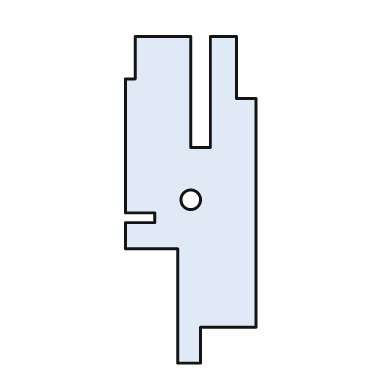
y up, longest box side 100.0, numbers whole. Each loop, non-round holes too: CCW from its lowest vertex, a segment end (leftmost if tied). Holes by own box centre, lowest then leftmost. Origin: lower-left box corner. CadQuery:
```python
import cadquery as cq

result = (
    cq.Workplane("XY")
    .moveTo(16.0, 0.0)
    .lineTo(23.0, 0.0)
    .lineTo(23.0, 11.0)
    .lineTo(40.0, 11.0)
    .lineTo(40.0, 81.0)
    .lineTo(34.0, 81.0)
    .lineTo(34.0, 100.0)
    .lineTo(26.0, 100.0)
    .lineTo(26.0, 66.0)
    .lineTo(20.0, 66.0)
    .lineTo(20.0, 100.0)
    .lineTo(3.0, 100.0)
    .lineTo(3.0, 87.0)
    .lineTo(0.0, 87.0)
    .lineTo(0.0, 46.0)
    .lineTo(9.0, 46.0)
    .lineTo(9.0, 43.0)
    .lineTo(0.0, 43.0)
    .lineTo(0.0, 35.0)
    .lineTo(16.0, 35.0)
    .close()
    .moveTo(20.0, 50.0)
    .circle(3.0)
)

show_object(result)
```